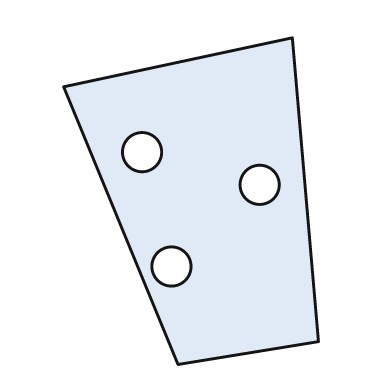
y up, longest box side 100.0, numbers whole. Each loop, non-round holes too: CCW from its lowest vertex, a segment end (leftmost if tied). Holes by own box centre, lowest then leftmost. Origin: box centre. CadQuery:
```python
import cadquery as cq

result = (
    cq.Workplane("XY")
    .moveTo(-4.0, -50.0)
    .lineTo(39.0, -43.0)
    .lineTo(31.0, 50.0)
    .lineTo(-39.0, 35.0)
    .close()
    .moveTo(-6.0, -20.0)
    .circle(6.0)
    .moveTo(21.0, 5.0)
    .circle(6.0)
    .moveTo(-15.0, 15.0)
    .circle(6.0)
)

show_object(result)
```